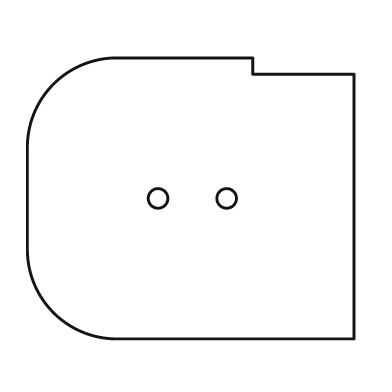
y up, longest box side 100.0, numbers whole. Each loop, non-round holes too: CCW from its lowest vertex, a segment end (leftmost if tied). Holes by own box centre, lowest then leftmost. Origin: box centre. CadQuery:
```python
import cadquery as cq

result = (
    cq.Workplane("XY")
    .moveTo(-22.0, -43.0)
    .lineTo(50.0, -43.0)
    .lineTo(50.0, 38.0)
    .lineTo(19.0, 38.0)
    .lineTo(19.0, 43.0)
    .lineTo(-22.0, 43.0)
    .threePointArc((-42.0, 35.0), (-50.0, 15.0))
    .lineTo(-50.0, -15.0)
    .threePointArc((-42.0, -35.0), (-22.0, -43.0))
    .close()
    .moveTo(-10.0, 0.0)
    .circle(3.0)
    .moveTo(11.0, 0.0)
    .circle(3.0)
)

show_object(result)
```